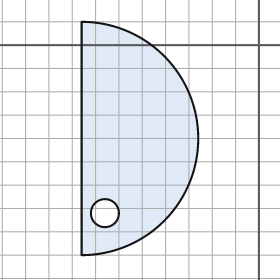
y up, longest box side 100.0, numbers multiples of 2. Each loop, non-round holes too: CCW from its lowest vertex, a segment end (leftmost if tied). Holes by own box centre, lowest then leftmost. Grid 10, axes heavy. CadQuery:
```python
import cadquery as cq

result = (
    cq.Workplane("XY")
    .moveTo(-76.0, -90.0)
    .threePointArc((-26.0, -40.0), (-76.0, 10.0))
    .close()
    .moveTo(-66.0, -72.0)
    .circle(6.0)
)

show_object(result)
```